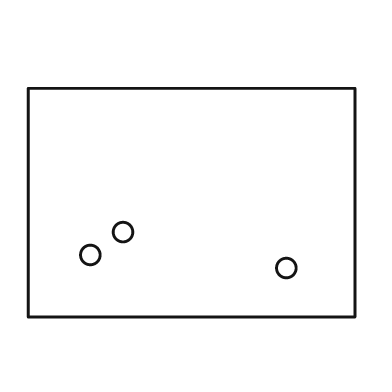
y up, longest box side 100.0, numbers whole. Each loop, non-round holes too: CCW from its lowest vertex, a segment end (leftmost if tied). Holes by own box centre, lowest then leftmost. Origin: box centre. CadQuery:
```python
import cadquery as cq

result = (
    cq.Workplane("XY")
    .moveTo(-50.0, -35.0)
    .lineTo(50.0, -35.0)
    .lineTo(50.0, 35.0)
    .lineTo(-50.0, 35.0)
    .close()
    .moveTo(29.0, -20.0)
    .circle(3.0)
    .moveTo(-31.0, -16.0)
    .circle(3.0)
    .moveTo(-21.0, -9.0)
    .circle(3.0)
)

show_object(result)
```